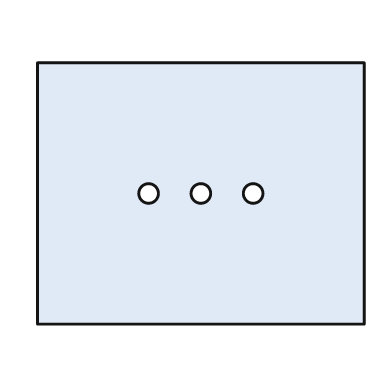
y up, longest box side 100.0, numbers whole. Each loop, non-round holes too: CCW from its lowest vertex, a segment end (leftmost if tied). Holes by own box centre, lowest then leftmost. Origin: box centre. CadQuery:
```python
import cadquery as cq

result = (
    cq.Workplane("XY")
    .moveTo(-50.0, -40.0)
    .lineTo(50.0, -40.0)
    .lineTo(50.0, 40.0)
    .lineTo(-50.0, 40.0)
    .close()
    .moveTo(-16.0, 0.0)
    .circle(3.0)
    .moveTo(0.0, 0.0)
    .circle(3.0)
    .moveTo(16.0, 0.0)
    .circle(3.0)
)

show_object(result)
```